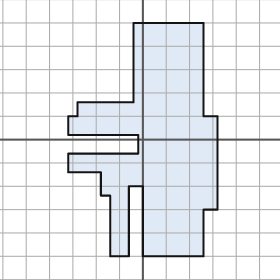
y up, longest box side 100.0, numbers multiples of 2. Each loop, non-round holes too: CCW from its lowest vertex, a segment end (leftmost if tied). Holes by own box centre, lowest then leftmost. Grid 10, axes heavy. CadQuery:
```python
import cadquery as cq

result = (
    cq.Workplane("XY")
    .moveTo(-14.0, -50.0)
    .lineTo(-6.0, -50.0)
    .lineTo(-6.0, -20.0)
    .lineTo(0.0, -20.0)
    .lineTo(0.0, -50.0)
    .lineTo(26.0, -50.0)
    .lineTo(26.0, -30.0)
    .lineTo(32.0, -30.0)
    .lineTo(32.0, 10.0)
    .lineTo(26.0, 10.0)
    .lineTo(26.0, 50.0)
    .lineTo(-4.0, 50.0)
    .lineTo(-4.0, 16.0)
    .lineTo(-28.0, 16.0)
    .lineTo(-28.0, 10.0)
    .lineTo(-32.0, 10.0)
    .lineTo(-32.0, 2.0)
    .lineTo(-2.0, 2.0)
    .lineTo(-2.0, -6.0)
    .lineTo(-32.0, -6.0)
    .lineTo(-32.0, -14.0)
    .lineTo(-18.0, -14.0)
    .lineTo(-18.0, -24.0)
    .lineTo(-14.0, -24.0)
    .close()
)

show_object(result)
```